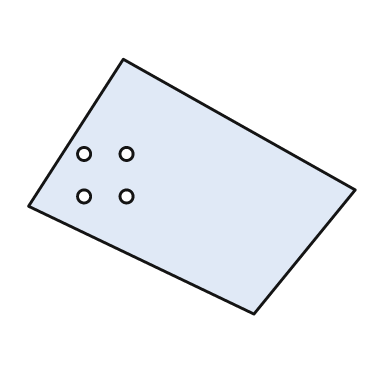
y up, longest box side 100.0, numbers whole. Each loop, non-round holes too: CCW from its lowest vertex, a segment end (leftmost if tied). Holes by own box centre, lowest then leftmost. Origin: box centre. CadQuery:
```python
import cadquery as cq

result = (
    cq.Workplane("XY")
    .moveTo(19.0, -39.0)
    .lineTo(50.0, -1.0)
    .lineTo(-21.0, 39.0)
    .lineTo(-50.0, -6.0)
    .close()
    .moveTo(-33.0, -3.0)
    .circle(2.0)
    .moveTo(-20.0, -3.0)
    .circle(2.0)
    .moveTo(-33.0, 10.0)
    .circle(2.0)
    .moveTo(-20.0, 10.0)
    .circle(2.0)
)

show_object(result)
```